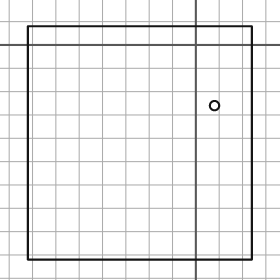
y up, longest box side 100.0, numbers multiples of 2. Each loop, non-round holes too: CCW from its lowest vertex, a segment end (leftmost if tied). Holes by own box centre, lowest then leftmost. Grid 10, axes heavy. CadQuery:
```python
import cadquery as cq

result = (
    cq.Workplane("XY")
    .moveTo(-72.0, -92.0)
    .lineTo(24.0, -92.0)
    .lineTo(24.0, 8.0)
    .lineTo(-72.0, 8.0)
    .close()
    .moveTo(8.0, -26.0)
    .circle(2.0)
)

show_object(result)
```